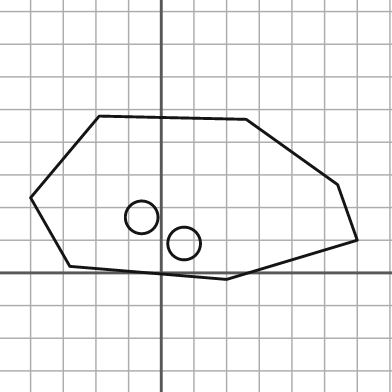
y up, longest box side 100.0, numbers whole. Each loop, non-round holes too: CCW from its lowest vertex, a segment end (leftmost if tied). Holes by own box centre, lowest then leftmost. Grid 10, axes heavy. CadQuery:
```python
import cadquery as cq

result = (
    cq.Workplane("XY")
    .moveTo(20.0, -2.0)
    .lineTo(60.0, 10.0)
    .lineTo(54.0, 27.0)
    .lineTo(26.0, 47.0)
    .lineTo(-19.0, 48.0)
    .lineTo(-40.0, 23.0)
    .lineTo(-28.0, 2.0)
    .close()
    .moveTo(7.0, 9.0)
    .circle(5.0)
    .moveTo(-6.0, 17.0)
    .circle(5.0)
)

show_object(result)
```